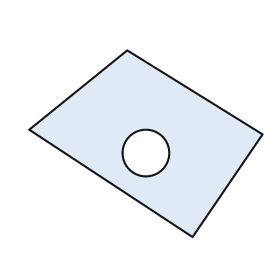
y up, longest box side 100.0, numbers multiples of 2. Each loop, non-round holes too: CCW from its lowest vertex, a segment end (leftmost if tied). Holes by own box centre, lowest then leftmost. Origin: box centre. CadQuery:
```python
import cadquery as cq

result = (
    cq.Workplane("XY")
    .moveTo(20.0, -40.0)
    .lineTo(50.0, 4.0)
    .lineTo(-8.0, 40.0)
    .lineTo(-50.0, 6.0)
    .close()
    .moveTo(0.0, -4.0)
    .circle(10.0)
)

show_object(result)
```